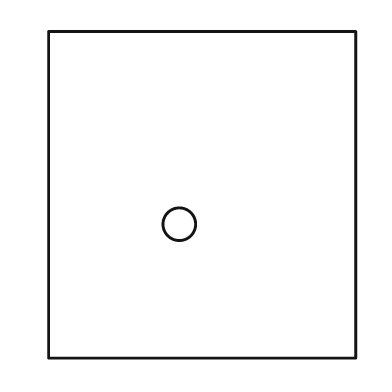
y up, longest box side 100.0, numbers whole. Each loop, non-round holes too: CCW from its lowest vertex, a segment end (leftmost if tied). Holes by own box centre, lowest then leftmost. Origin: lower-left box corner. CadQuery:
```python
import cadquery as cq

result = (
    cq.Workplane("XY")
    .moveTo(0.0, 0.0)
    .lineTo(94.0, 0.0)
    .lineTo(94.0, 100.0)
    .lineTo(0.0, 100.0)
    .close()
    .moveTo(40.0, 41.0)
    .circle(5.0)
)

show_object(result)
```